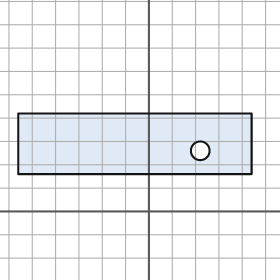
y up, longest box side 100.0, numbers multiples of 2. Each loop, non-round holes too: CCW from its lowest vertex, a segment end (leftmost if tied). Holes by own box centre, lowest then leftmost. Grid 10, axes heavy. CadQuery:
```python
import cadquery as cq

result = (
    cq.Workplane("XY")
    .moveTo(-56.0, 16.0)
    .lineTo(44.0, 16.0)
    .lineTo(44.0, 42.0)
    .lineTo(-56.0, 42.0)
    .close()
    .moveTo(22.0, 26.0)
    .circle(4.0)
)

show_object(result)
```